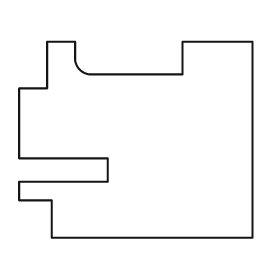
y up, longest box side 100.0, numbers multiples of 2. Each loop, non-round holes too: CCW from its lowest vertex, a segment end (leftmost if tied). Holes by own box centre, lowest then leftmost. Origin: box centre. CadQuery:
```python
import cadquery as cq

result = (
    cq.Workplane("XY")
    .moveTo(-36.0, -42.0)
    .lineTo(50.0, -42.0)
    .lineTo(50.0, 42.0)
    .lineTo(20.0, 42.0)
    .lineTo(20.0, 28.0)
    .lineTo(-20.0, 28.0)
    .threePointArc((-24.0, 30.0), (-26.0, 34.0))
    .lineTo(-26.0, 42.0)
    .lineTo(-38.0, 42.0)
    .lineTo(-38.0, 22.0)
    .lineTo(-50.0, 22.0)
    .lineTo(-50.0, -8.0)
    .lineTo(-12.0, -8.0)
    .lineTo(-12.0, -18.0)
    .lineTo(-50.0, -18.0)
    .lineTo(-50.0, -26.0)
    .lineTo(-36.0, -26.0)
    .close()
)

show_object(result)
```